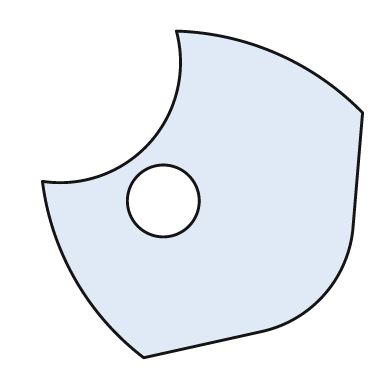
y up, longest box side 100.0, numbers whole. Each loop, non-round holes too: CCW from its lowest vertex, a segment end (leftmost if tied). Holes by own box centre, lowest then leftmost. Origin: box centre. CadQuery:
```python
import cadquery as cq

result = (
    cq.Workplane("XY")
    .moveTo(-18.0, -50.0)
    .lineTo(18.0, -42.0)
    .threePointArc((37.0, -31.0), (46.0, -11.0))
    .lineTo(49.0, 25.0)
    .threePointArc((23.0, 43.0), (-8.0, 50.0))
    .threePointArc((-16.0, 16.0), (-49.0, 4.0))
    .threePointArc((-39.0, -26.0), (-18.0, -50.0))
    .close()
    .moveTo(-12.0, -2.0)
    .circle(11.0)
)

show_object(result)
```